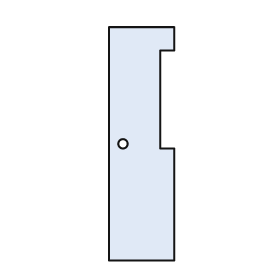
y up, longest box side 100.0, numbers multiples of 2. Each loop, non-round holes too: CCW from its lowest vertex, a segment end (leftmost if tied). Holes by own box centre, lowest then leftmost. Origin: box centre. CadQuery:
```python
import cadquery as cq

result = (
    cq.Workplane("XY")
    .moveTo(-14.0, -50.0)
    .lineTo(14.0, -50.0)
    .lineTo(14.0, -2.0)
    .lineTo(8.0, -2.0)
    .lineTo(8.0, 40.0)
    .lineTo(14.0, 40.0)
    .lineTo(14.0, 50.0)
    .lineTo(-14.0, 50.0)
    .close()
    .moveTo(-8.0, 0.0)
    .circle(2.0)
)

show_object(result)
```